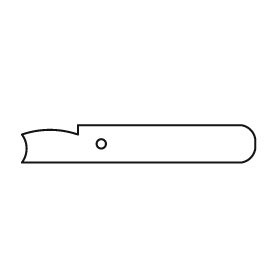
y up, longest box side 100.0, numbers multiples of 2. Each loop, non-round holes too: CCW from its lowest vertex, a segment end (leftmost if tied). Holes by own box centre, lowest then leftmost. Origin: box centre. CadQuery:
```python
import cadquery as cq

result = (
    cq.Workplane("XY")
    .moveTo(-50.0, -8.0)
    .lineTo(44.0, -8.0)
    .threePointArc((48.0, -6.0), (50.0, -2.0))
    .lineTo(50.0, 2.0)
    .threePointArc((48.0, 6.0), (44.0, 8.0))
    .lineTo(-26.0, 8.0)
    .lineTo(-26.0, 4.0)
    .threePointArc((-38.0, 6.0), (-50.0, 4.0))
    .threePointArc((-48.0, -2.0), (-50.0, -8.0))
    .close()
    .moveTo(-16.0, 0.0)
    .circle(2.0)
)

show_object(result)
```